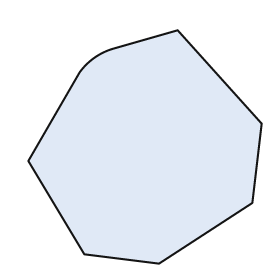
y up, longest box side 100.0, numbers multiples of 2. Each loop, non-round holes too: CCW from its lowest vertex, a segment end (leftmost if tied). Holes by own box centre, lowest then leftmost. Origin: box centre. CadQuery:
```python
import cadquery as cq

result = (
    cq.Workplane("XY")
    .moveTo(6.0, -50.0)
    .lineTo(46.0, -24.0)
    .lineTo(50.0, 10.0)
    .lineTo(14.0, 50.0)
    .lineTo(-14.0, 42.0)
    .threePointArc((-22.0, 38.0), (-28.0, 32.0))
    .lineTo(-50.0, -6.0)
    .lineTo(-26.0, -46.0)
    .close()
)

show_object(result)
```